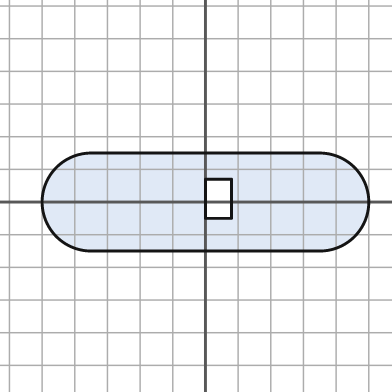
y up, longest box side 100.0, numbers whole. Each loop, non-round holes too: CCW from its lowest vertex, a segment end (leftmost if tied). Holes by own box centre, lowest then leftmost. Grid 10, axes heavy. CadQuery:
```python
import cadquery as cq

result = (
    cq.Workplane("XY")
    .moveTo(-35.0, -15.0)
    .lineTo(35.0, -15.0)
    .threePointArc((50.0, 0.0), (35.0, 15.0))
    .lineTo(-35.0, 15.0)
    .threePointArc((-50.0, 0.0), (-35.0, -15.0))
    .close()
    .moveTo(0.0, -5.0)
    .lineTo(8.0, -5.0)
    .lineTo(8.0, 7.0)
    .lineTo(0.0, 7.0)
    .close()
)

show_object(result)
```